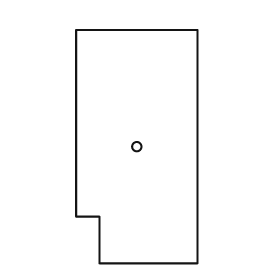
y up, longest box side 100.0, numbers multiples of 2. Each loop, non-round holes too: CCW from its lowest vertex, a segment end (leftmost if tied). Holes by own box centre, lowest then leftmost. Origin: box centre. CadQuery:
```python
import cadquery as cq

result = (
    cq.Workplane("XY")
    .moveTo(-16.0, -50.0)
    .lineTo(26.0, -50.0)
    .lineTo(26.0, 50.0)
    .lineTo(-26.0, 50.0)
    .lineTo(-26.0, -30.0)
    .lineTo(-16.0, -30.0)
    .close()
    .moveTo(0.0, 0.0)
    .circle(2.0)
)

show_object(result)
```